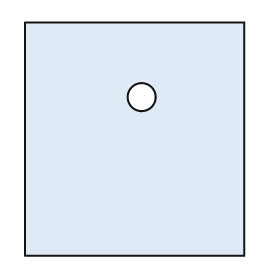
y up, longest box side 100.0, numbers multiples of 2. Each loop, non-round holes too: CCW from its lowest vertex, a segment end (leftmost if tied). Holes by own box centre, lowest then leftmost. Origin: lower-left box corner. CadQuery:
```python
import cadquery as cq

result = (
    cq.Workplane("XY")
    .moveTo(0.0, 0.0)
    .lineTo(94.0, 0.0)
    .lineTo(94.0, 100.0)
    .lineTo(0.0, 100.0)
    .close()
    .moveTo(50.0, 68.0)
    .circle(6.0)
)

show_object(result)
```